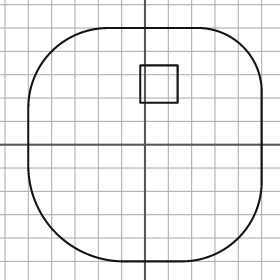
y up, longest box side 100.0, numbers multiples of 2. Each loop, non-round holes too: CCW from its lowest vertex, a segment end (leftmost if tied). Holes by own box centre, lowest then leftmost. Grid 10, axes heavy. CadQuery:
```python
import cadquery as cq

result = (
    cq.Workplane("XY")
    .moveTo(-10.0, -50.0)
    .lineTo(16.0, -50.0)
    .threePointArc((40.0, -40.0), (50.0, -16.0))
    .lineTo(50.0, 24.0)
    .threePointArc((42.0, 42.0), (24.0, 50.0))
    .lineTo(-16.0, 50.0)
    .threePointArc((-40.0, 40.0), (-50.0, 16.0))
    .lineTo(-50.0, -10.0)
    .threePointArc((-38.0, -38.0), (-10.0, -50.0))
    .close()
    .moveTo(-2.0, 18.0)
    .lineTo(14.0, 18.0)
    .lineTo(14.0, 34.0)
    .lineTo(-2.0, 34.0)
    .close()
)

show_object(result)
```